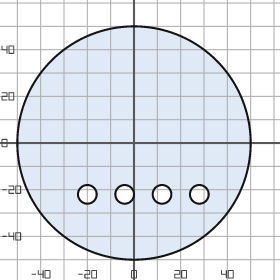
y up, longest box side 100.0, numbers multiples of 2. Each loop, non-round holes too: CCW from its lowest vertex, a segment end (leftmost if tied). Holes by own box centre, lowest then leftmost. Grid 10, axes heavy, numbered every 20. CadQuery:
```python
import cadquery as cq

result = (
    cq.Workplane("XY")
    .moveTo(0.0, 0.0)
    .circle(50.0)
    .moveTo(-20.0, -22.0)
    .circle(4.0)
    .moveTo(-4.0, -22.0)
    .circle(4.0)
    .moveTo(12.0, -22.0)
    .circle(4.0)
    .moveTo(28.0, -22.0)
    .circle(4.0)
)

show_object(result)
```